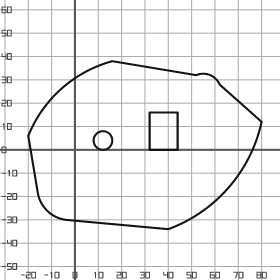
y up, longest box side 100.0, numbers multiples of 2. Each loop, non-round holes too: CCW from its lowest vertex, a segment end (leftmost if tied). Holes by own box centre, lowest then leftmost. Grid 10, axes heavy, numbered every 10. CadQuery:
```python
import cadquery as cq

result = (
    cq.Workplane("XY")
    .moveTo(40.0, -34.0)
    .threePointArc((66.0, -16.0), (80.0, 12.0))
    .lineTo(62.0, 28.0)
    .threePointArc((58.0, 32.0), (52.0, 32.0))
    .lineTo(16.0, 38.0)
    .threePointArc((-6.0, 26.0), (-20.0, 6.0))
    .lineTo(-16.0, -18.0)
    .threePointArc((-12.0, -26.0), (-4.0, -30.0))
    .close()
    .moveTo(12.0, 4.0)
    .circle(4.0)
    .moveTo(32.0, 0.0)
    .lineTo(44.0, 0.0)
    .lineTo(44.0, 16.0)
    .lineTo(32.0, 16.0)
    .close()
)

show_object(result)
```